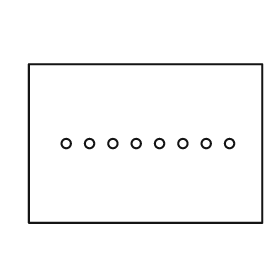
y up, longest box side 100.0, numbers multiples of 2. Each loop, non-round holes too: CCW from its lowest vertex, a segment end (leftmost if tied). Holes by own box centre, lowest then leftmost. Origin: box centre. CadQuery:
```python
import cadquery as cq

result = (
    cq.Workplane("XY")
    .moveTo(-50.0, -34.0)
    .lineTo(50.0, -34.0)
    .lineTo(50.0, 34.0)
    .lineTo(-50.0, 34.0)
    .close()
    .moveTo(-34.0, 0.0)
    .circle(2.0)
    .moveTo(-24.0, 0.0)
    .circle(2.0)
    .moveTo(-14.0, 0.0)
    .circle(2.0)
    .moveTo(-4.0, 0.0)
    .circle(2.0)
    .moveTo(6.0, 0.0)
    .circle(2.0)
    .moveTo(16.0, 0.0)
    .circle(2.0)
    .moveTo(26.0, 0.0)
    .circle(2.0)
    .moveTo(36.0, 0.0)
    .circle(2.0)
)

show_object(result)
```